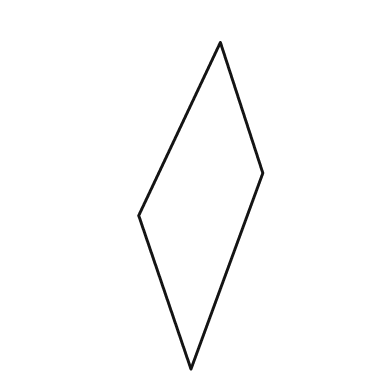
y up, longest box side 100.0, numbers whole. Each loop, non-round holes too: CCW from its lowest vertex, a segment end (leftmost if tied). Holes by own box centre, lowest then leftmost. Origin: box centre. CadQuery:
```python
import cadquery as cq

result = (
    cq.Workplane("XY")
    .moveTo(-3.0, -50.0)
    .lineTo(19.0, 10.0)
    .lineTo(6.0, 50.0)
    .lineTo(-19.0, -3.0)
    .close()
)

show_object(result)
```